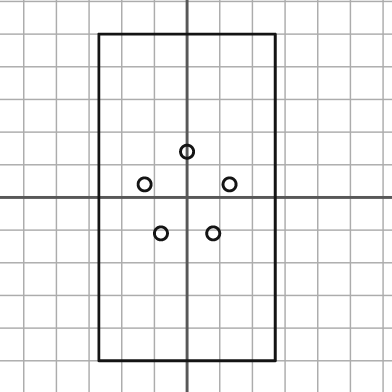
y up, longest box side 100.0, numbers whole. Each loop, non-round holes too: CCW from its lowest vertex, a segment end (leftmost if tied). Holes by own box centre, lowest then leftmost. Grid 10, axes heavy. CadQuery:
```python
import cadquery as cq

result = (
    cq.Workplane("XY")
    .moveTo(-27.0, -50.0)
    .lineTo(27.0, -50.0)
    .lineTo(27.0, 50.0)
    .lineTo(-27.0, 50.0)
    .close()
    .moveTo(-8.0, -11.0)
    .circle(2.0)
    .moveTo(8.0, -11.0)
    .circle(2.0)
    .moveTo(-13.0, 4.0)
    .circle(2.0)
    .moveTo(13.0, 4.0)
    .circle(2.0)
    .moveTo(0.0, 14.0)
    .circle(2.0)
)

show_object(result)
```